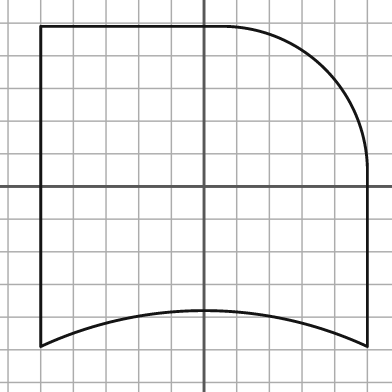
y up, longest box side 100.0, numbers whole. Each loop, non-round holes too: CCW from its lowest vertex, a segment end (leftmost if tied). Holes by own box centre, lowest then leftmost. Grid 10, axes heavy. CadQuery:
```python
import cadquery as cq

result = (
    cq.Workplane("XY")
    .moveTo(-50.0, -49.0)
    .threePointArc((0.0, -38.0), (50.0, -49.0))
    .lineTo(50.0, 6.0)
    .threePointArc((37.0, 36.0), (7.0, 49.0))
    .lineTo(-50.0, 49.0)
    .close()
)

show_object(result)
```